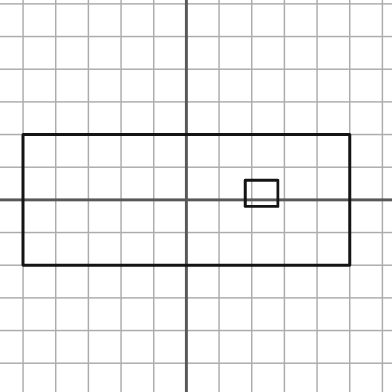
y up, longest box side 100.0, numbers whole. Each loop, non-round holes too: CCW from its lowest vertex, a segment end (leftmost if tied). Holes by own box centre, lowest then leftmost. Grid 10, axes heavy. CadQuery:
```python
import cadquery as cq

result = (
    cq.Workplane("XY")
    .moveTo(-50.0, -20.0)
    .lineTo(50.0, -20.0)
    .lineTo(50.0, 20.0)
    .lineTo(-50.0, 20.0)
    .close()
    .moveTo(18.0, -2.0)
    .lineTo(28.0, -2.0)
    .lineTo(28.0, 6.0)
    .lineTo(18.0, 6.0)
    .close()
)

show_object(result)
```